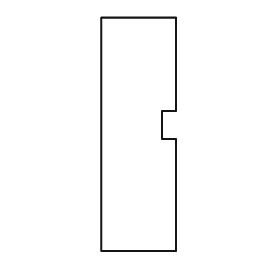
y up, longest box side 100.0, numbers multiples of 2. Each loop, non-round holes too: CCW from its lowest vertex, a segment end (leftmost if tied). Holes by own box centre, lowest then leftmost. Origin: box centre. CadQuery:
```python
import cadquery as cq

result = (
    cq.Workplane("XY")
    .moveTo(-16.0, -50.0)
    .lineTo(16.0, -50.0)
    .lineTo(16.0, -2.0)
    .lineTo(10.0, -2.0)
    .lineTo(10.0, 10.0)
    .lineTo(16.0, 10.0)
    .lineTo(16.0, 50.0)
    .lineTo(-16.0, 50.0)
    .close()
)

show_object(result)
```